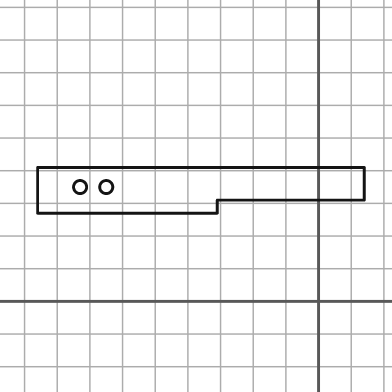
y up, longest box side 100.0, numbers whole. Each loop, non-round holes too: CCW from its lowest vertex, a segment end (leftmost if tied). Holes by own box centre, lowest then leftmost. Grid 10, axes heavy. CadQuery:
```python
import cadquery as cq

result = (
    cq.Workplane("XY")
    .moveTo(-86.0, 27.0)
    .lineTo(-31.0, 27.0)
    .lineTo(-31.0, 31.0)
    .lineTo(14.0, 31.0)
    .lineTo(14.0, 41.0)
    .lineTo(-86.0, 41.0)
    .close()
    .moveTo(-73.0, 35.0)
    .circle(2.0)
    .moveTo(-65.0, 35.0)
    .circle(2.0)
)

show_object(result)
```